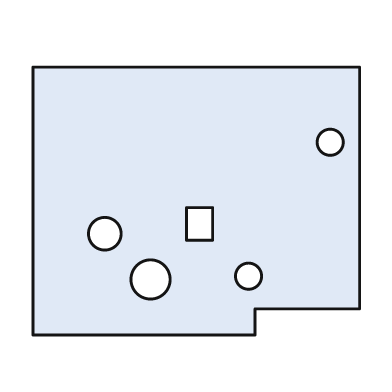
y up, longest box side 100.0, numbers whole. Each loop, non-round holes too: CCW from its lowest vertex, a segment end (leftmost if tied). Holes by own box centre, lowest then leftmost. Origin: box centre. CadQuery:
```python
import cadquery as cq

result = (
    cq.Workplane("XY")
    .moveTo(-50.0, -41.0)
    .lineTo(18.0, -41.0)
    .lineTo(18.0, -33.0)
    .lineTo(50.0, -33.0)
    .lineTo(50.0, 41.0)
    .lineTo(-50.0, 41.0)
    .close()
    .moveTo(-14.0, -24.0)
    .circle(6.0)
    .moveTo(16.0, -23.0)
    .circle(4.0)
    .moveTo(-28.0, -10.0)
    .circle(5.0)
    .moveTo(-3.0, -12.0)
    .lineTo(5.0, -12.0)
    .lineTo(5.0, -2.0)
    .lineTo(-3.0, -2.0)
    .close()
    .moveTo(41.0, 18.0)
    .circle(4.0)
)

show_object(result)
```